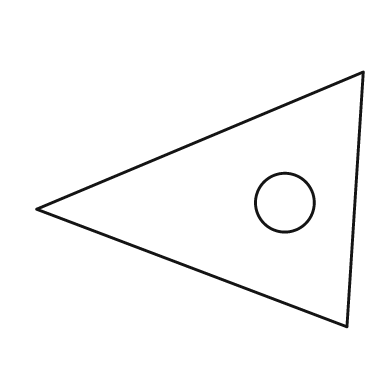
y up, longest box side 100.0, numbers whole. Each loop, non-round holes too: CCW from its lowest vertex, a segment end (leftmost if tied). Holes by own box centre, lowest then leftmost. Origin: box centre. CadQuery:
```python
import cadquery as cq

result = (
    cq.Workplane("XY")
    .moveTo(45.0, -39.0)
    .lineTo(50.0, 39.0)
    .lineTo(-50.0, -3.0)
    .close()
    .moveTo(26.0, -1.0)
    .circle(9.0)
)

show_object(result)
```